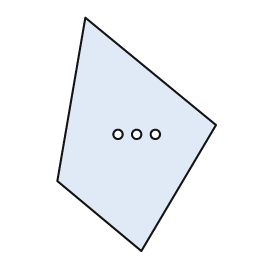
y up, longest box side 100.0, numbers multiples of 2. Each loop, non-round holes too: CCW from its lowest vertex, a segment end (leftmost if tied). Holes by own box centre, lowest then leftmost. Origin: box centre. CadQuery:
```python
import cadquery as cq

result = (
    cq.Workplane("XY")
    .moveTo(2.0, -50.0)
    .lineTo(34.0, 4.0)
    .lineTo(-22.0, 50.0)
    .lineTo(-34.0, -20.0)
    .close()
    .moveTo(-8.0, 0.0)
    .circle(2.0)
    .moveTo(0.0, 0.0)
    .circle(2.0)
    .moveTo(8.0, 0.0)
    .circle(2.0)
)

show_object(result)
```